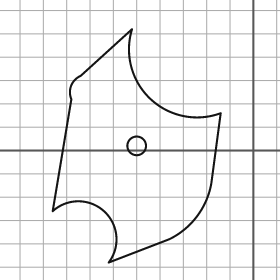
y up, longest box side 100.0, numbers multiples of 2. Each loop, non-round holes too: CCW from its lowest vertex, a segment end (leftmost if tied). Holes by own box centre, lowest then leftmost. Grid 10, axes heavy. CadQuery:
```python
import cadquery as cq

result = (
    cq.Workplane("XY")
    .moveTo(-62.0, -48.0)
    .lineTo(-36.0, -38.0)
    .threePointArc((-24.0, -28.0), (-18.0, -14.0))
    .lineTo(-14.0, 16.0)
    .threePointArc((-44.0, 22.0), (-52.0, 52.0))
    .lineTo(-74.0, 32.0)
    .threePointArc((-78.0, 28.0), (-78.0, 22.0))
    .lineTo(-86.0, -26.0)
    .threePointArc((-64.0, -26.0), (-62.0, -48.0))
    .close()
    .moveTo(-50.0, 2.0)
    .circle(4.0)
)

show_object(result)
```